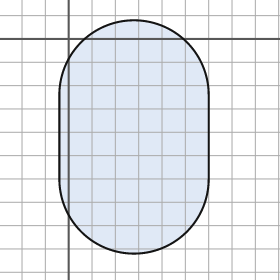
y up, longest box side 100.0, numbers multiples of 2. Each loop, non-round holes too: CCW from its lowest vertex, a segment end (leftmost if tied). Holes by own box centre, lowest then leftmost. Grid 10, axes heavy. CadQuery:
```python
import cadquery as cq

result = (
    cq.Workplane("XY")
    .moveTo(-4.0, -60.0)
    .threePointArc((28.0, -92.0), (60.0, -60.0))
    .lineTo(60.0, -24.0)
    .threePointArc((28.0, 8.0), (-4.0, -24.0))
    .close()
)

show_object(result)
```